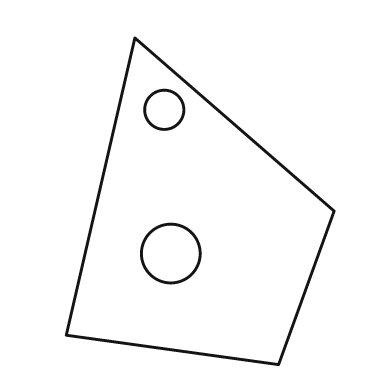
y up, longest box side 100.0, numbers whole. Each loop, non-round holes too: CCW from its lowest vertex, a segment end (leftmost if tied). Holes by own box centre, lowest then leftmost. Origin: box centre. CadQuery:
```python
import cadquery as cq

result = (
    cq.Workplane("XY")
    .moveTo(24.0, -50.0)
    .lineTo(41.0, -3.0)
    .lineTo(-20.0, 50.0)
    .lineTo(-41.0, -41.0)
    .close()
    .moveTo(-9.0, -16.0)
    .circle(9.0)
    .moveTo(-11.0, 28.0)
    .circle(6.0)
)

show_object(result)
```